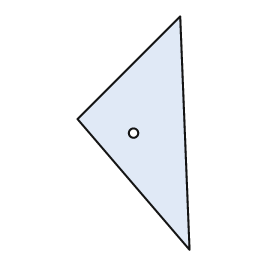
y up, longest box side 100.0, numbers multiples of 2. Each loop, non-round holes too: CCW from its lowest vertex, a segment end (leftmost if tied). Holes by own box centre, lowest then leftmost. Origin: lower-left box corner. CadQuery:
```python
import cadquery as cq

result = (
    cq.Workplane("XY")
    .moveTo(48.0, 0.0)
    .lineTo(44.0, 100.0)
    .lineTo(0.0, 56.0)
    .close()
    .moveTo(24.0, 50.0)
    .circle(2.0)
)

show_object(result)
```